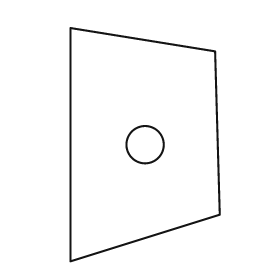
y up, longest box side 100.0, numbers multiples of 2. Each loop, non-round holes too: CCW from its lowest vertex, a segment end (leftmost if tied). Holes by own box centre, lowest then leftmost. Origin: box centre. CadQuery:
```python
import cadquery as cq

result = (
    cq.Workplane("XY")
    .moveTo(-32.0, -50.0)
    .lineTo(32.0, -30.0)
    .lineTo(30.0, 40.0)
    .lineTo(-32.0, 50.0)
    .close()
    .moveTo(0.0, 0.0)
    .circle(8.0)
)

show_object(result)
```